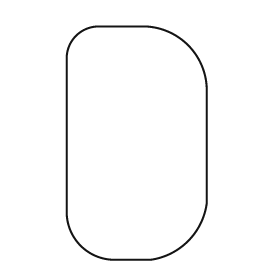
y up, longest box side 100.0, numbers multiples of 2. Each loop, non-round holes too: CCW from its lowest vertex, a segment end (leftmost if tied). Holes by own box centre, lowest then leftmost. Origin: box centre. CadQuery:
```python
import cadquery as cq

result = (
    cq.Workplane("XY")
    .moveTo(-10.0, -50.0)
    .lineTo(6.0, -50.0)
    .threePointArc((22.0, -42.0), (30.0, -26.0))
    .lineTo(30.0, 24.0)
    .threePointArc((22.0, 42.0), (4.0, 50.0))
    .lineTo(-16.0, 50.0)
    .threePointArc((-26.0, 46.0), (-30.0, 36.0))
    .lineTo(-30.0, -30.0)
    .threePointArc((-24.0, -44.0), (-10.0, -50.0))
    .close()
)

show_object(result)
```